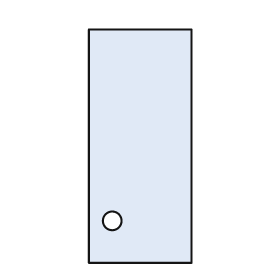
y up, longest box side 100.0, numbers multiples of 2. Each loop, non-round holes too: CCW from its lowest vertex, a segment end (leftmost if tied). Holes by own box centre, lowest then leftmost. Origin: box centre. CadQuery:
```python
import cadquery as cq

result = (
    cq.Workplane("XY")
    .moveTo(-22.0, -50.0)
    .lineTo(22.0, -50.0)
    .lineTo(22.0, 50.0)
    .lineTo(-22.0, 50.0)
    .close()
    .moveTo(-12.0, -32.0)
    .circle(4.0)
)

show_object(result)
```